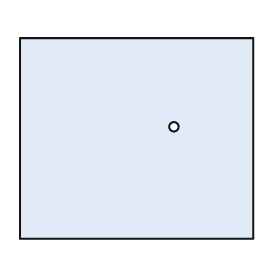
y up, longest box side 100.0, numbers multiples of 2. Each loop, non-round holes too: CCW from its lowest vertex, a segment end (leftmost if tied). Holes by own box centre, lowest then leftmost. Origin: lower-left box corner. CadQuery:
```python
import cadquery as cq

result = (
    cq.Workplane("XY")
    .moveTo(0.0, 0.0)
    .lineTo(100.0, 0.0)
    .lineTo(100.0, 86.0)
    .lineTo(0.0, 86.0)
    .close()
    .moveTo(66.0, 48.0)
    .circle(2.0)
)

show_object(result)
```